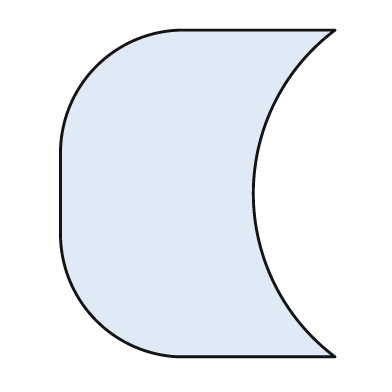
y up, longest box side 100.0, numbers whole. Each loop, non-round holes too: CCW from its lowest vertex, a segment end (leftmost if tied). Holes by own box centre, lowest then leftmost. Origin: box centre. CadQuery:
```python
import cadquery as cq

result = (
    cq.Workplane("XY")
    .moveTo(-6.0, -50.0)
    .lineTo(42.0, -50.0)
    .threePointArc((17.0, 0.0), (42.0, 50.0))
    .lineTo(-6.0, 50.0)
    .threePointArc((-31.0, 39.0), (-42.0, 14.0))
    .lineTo(-42.0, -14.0)
    .threePointArc((-31.0, -39.0), (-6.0, -50.0))
    .close()
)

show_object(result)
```